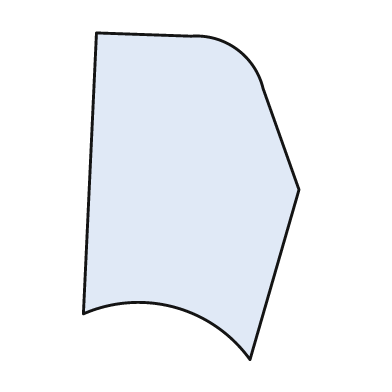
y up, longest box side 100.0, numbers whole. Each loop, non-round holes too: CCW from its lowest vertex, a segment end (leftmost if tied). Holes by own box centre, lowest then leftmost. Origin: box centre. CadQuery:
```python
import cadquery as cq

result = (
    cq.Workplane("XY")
    .moveTo(18.0, -50.0)
    .lineTo(33.0, 2.0)
    .lineTo(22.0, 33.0)
    .threePointArc((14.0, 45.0), (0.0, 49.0))
    .lineTo(-29.0, 50.0)
    .lineTo(-33.0, -36.0)
    .threePointArc((-5.0, -34.0), (18.0, -50.0))
    .close()
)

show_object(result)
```